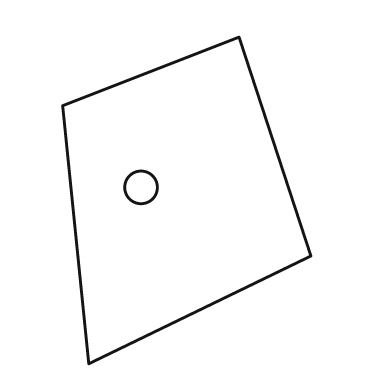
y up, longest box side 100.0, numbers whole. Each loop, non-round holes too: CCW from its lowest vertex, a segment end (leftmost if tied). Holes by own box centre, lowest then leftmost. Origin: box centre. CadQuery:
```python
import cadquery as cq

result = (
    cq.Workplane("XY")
    .moveTo(-30.0, -50.0)
    .lineTo(38.0, -17.0)
    .lineTo(16.0, 50.0)
    .lineTo(-38.0, 29.0)
    .close()
    .moveTo(-14.0, 4.0)
    .circle(5.0)
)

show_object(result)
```